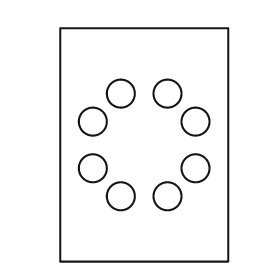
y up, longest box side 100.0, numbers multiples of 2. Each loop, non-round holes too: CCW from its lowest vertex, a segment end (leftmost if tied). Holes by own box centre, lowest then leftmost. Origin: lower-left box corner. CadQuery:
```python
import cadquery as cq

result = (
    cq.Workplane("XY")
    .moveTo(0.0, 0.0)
    .lineTo(72.0, 0.0)
    .lineTo(72.0, 100.0)
    .lineTo(0.0, 100.0)
    .close()
    .moveTo(26.0, 28.0)
    .circle(6.0)
    .moveTo(46.0, 28.0)
    .circle(6.0)
    .moveTo(14.0, 40.0)
    .circle(6.0)
    .moveTo(58.0, 40.0)
    .circle(6.0)
    .moveTo(14.0, 60.0)
    .circle(6.0)
    .moveTo(58.0, 60.0)
    .circle(6.0)
    .moveTo(26.0, 72.0)
    .circle(6.0)
    .moveTo(46.0, 72.0)
    .circle(6.0)
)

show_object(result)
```